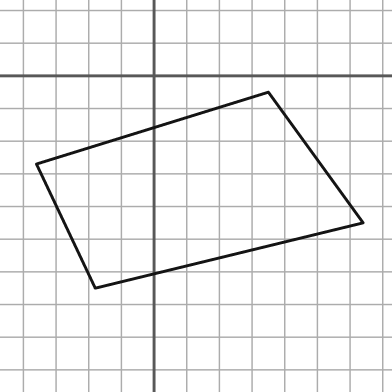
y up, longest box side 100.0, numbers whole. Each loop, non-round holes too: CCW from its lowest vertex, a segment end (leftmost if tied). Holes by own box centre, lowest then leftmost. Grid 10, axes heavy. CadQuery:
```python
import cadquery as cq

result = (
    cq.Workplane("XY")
    .moveTo(-18.0, -65.0)
    .lineTo(64.0, -45.0)
    .lineTo(35.0, -5.0)
    .lineTo(-36.0, -27.0)
    .close()
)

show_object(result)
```